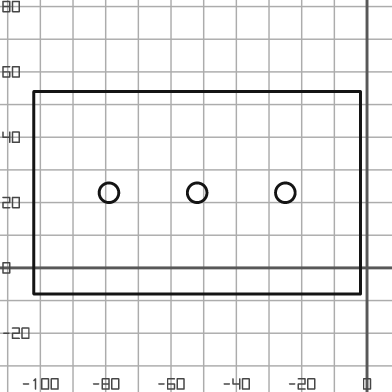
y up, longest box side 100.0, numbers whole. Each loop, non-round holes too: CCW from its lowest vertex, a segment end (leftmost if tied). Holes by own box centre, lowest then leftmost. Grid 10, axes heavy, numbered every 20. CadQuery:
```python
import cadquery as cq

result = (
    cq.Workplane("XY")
    .moveTo(-102.0, -8.0)
    .lineTo(-2.0, -8.0)
    .lineTo(-2.0, 54.0)
    .lineTo(-102.0, 54.0)
    .close()
    .moveTo(-79.0, 23.0)
    .circle(3.0)
    .moveTo(-52.0, 23.0)
    .circle(3.0)
    .moveTo(-25.0, 23.0)
    .circle(3.0)
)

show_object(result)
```